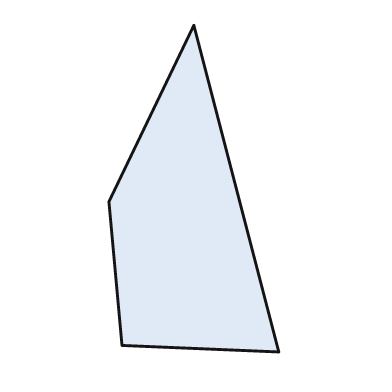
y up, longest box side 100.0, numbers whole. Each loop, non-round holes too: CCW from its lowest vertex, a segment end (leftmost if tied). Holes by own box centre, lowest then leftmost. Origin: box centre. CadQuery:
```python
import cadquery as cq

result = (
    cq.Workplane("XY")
    .moveTo(26.0, -50.0)
    .lineTo(0.0, 50.0)
    .lineTo(-26.0, -4.0)
    .lineTo(-22.0, -48.0)
    .close()
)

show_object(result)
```